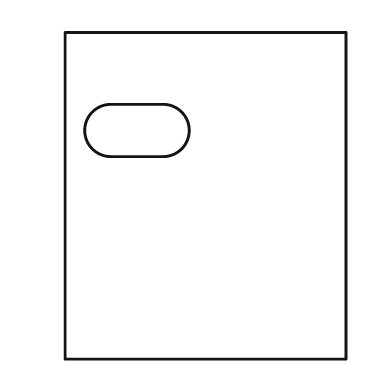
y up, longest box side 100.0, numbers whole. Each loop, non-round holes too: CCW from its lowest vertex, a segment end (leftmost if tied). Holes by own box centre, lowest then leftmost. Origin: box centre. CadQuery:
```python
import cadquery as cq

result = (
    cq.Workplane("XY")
    .moveTo(-43.0, -50.0)
    .lineTo(43.0, -50.0)
    .lineTo(43.0, 50.0)
    .lineTo(-43.0, 50.0)
    .close()
    .moveTo(-29.0, 12.0)
    .lineTo(-13.0, 12.0)
    .threePointArc((-5.0, 20.0), (-13.0, 28.0))
    .lineTo(-29.0, 28.0)
    .threePointArc((-37.0, 20.0), (-29.0, 12.0))
    .close()
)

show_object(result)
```